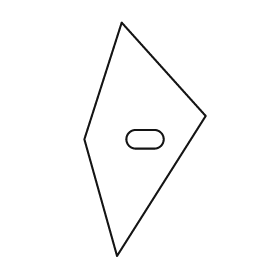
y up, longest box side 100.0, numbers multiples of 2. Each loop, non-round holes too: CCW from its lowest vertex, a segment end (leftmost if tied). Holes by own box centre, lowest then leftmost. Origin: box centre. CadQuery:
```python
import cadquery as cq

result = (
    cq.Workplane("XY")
    .moveTo(-12.0, -50.0)
    .lineTo(26.0, 10.0)
    .lineTo(-10.0, 50.0)
    .lineTo(-26.0, 0.0)
    .close()
    .moveTo(-4.0, -4.0)
    .lineTo(4.0, -4.0)
    .threePointArc((8.0, 0.0), (4.0, 4.0))
    .lineTo(-4.0, 4.0)
    .threePointArc((-8.0, 0.0), (-4.0, -4.0))
    .close()
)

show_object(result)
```